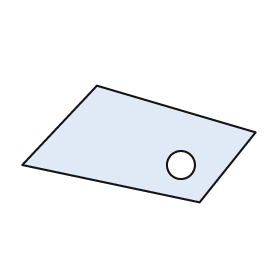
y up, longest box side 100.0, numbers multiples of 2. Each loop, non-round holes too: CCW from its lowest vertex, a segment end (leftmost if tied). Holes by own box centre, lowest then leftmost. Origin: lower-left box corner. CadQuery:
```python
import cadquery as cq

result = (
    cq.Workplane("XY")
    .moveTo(76.0, 0.0)
    .lineTo(100.0, 30.0)
    .lineTo(32.0, 50.0)
    .lineTo(0.0, 16.0)
    .close()
    .moveTo(68.0, 16.0)
    .circle(6.0)
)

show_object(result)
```